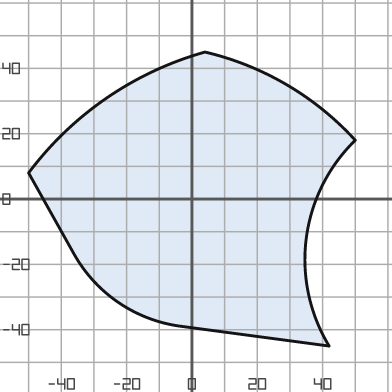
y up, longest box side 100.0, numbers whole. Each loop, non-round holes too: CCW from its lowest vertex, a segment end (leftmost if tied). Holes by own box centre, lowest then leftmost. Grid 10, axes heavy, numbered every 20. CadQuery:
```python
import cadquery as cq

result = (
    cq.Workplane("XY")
    .moveTo(42.0, -45.0)
    .threePointArc((35.0, -12.0), (50.0, 18.0))
    .threePointArc((29.0, 35.0), (4.0, 45.0))
    .threePointArc((-26.0, 31.0), (-50.0, 8.0))
    .lineTo(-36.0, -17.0)
    .threePointArc((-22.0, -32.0), (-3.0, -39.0))
    .close()
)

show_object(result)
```